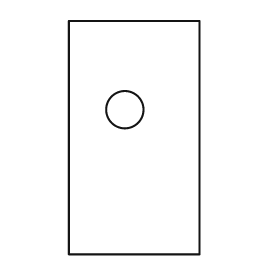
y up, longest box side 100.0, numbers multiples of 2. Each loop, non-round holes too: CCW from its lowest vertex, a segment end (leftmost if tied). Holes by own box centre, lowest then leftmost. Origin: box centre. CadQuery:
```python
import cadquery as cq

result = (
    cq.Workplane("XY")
    .moveTo(-28.0, -50.0)
    .lineTo(28.0, -50.0)
    .lineTo(28.0, 50.0)
    .lineTo(-28.0, 50.0)
    .close()
    .moveTo(-4.0, 12.0)
    .circle(8.0)
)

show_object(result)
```